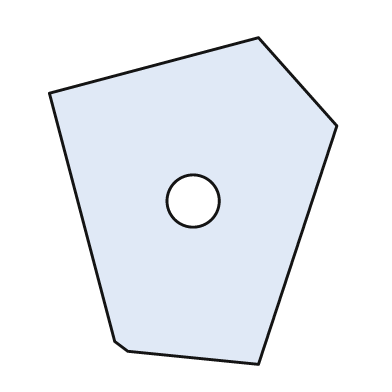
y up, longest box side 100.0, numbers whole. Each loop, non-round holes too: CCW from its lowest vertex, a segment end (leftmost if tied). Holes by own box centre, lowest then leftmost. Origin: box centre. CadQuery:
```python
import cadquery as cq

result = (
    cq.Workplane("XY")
    .moveTo(20.0, -50.0)
    .lineTo(44.0, 23.0)
    .lineTo(20.0, 50.0)
    .lineTo(-44.0, 33.0)
    .lineTo(-24.0, -43.0)
    .lineTo(-20.0, -46.0)
    .close()
    .moveTo(0.0, 0.0)
    .circle(8.0)
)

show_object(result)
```